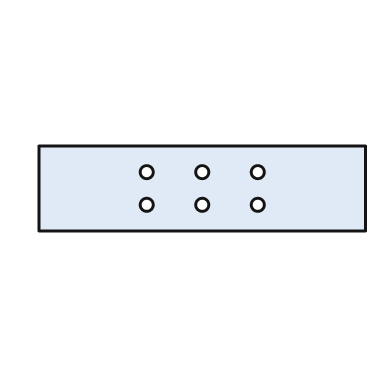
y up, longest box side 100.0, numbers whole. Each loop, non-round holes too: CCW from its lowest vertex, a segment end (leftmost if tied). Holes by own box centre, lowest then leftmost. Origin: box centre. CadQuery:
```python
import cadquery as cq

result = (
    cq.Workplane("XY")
    .moveTo(-50.0, -13.0)
    .lineTo(50.0, -13.0)
    .lineTo(50.0, 13.0)
    .lineTo(-50.0, 13.0)
    .close()
    .moveTo(-17.0, -5.0)
    .circle(2.0)
    .moveTo(0.0, -5.0)
    .circle(2.0)
    .moveTo(17.0, -5.0)
    .circle(2.0)
    .moveTo(-17.0, 5.0)
    .circle(2.0)
    .moveTo(0.0, 5.0)
    .circle(2.0)
    .moveTo(17.0, 5.0)
    .circle(2.0)
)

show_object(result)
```